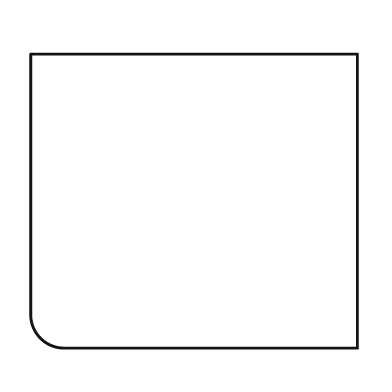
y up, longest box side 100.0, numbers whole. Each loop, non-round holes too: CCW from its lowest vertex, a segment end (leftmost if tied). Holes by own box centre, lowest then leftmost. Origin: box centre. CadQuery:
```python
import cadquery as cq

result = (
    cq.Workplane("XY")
    .moveTo(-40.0, -45.0)
    .lineTo(50.0, -45.0)
    .lineTo(50.0, 45.0)
    .lineTo(-50.0, 45.0)
    .lineTo(-50.0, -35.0)
    .threePointArc((-47.0, -42.0), (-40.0, -45.0))
    .close()
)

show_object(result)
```